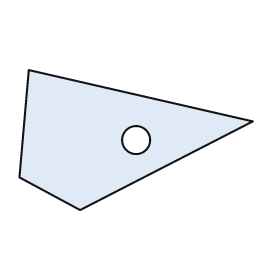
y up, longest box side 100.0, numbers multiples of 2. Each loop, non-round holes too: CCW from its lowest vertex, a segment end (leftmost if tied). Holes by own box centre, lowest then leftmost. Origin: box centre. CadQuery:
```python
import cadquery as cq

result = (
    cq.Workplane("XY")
    .moveTo(-24.0, -30.0)
    .lineTo(50.0, 8.0)
    .lineTo(-46.0, 30.0)
    .lineTo(-50.0, -16.0)
    .close()
    .moveTo(0.0, 0.0)
    .circle(6.0)
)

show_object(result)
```